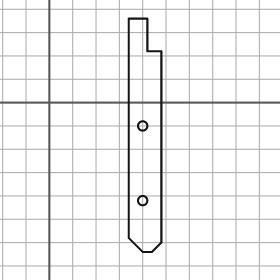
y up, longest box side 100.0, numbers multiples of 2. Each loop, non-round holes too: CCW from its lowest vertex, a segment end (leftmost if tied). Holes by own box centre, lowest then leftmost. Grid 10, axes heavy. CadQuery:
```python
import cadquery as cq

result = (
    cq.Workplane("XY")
    .moveTo(40.0, -64.0)
    .lineTo(44.0, -64.0)
    .lineTo(48.0, -60.0)
    .lineTo(48.0, 22.0)
    .lineTo(42.0, 22.0)
    .lineTo(42.0, 36.0)
    .lineTo(34.0, 36.0)
    .lineTo(34.0, -58.0)
    .close()
    .moveTo(40.0, -42.0)
    .circle(2.0)
    .moveTo(40.0, -10.0)
    .circle(2.0)
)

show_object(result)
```